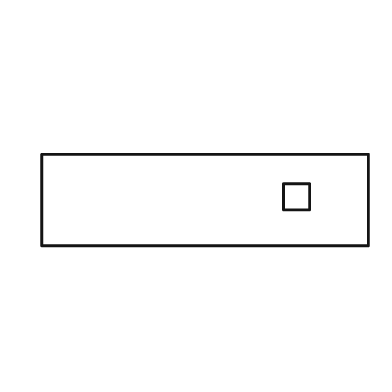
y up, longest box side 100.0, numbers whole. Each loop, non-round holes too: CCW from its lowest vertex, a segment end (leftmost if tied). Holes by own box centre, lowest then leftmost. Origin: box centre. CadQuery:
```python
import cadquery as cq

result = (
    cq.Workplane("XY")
    .moveTo(-50.0, -14.0)
    .lineTo(50.0, -14.0)
    .lineTo(50.0, 14.0)
    .lineTo(-50.0, 14.0)
    .close()
    .moveTo(24.0, -3.0)
    .lineTo(32.0, -3.0)
    .lineTo(32.0, 5.0)
    .lineTo(24.0, 5.0)
    .close()
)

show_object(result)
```